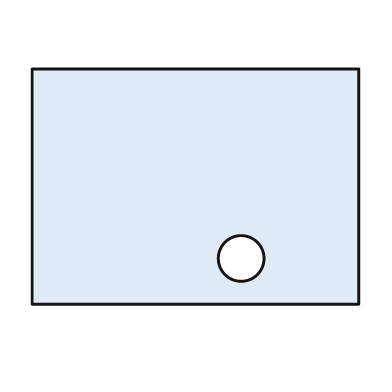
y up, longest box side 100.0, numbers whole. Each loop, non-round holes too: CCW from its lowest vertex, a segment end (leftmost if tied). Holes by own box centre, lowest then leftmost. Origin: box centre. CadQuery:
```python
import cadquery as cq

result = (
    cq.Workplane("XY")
    .moveTo(-50.0, -36.0)
    .lineTo(50.0, -36.0)
    .lineTo(50.0, 36.0)
    .lineTo(-50.0, 36.0)
    .close()
    .moveTo(14.0, -22.0)
    .circle(7.0)
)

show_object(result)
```